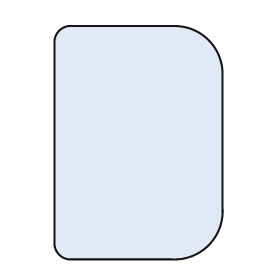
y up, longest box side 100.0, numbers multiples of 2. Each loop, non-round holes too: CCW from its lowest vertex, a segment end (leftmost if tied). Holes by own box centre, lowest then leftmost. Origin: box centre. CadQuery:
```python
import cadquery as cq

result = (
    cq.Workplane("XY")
    .moveTo(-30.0, -50.0)
    .lineTo(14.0, -50.0)
    .threePointArc((30.0, -44.0), (36.0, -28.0))
    .lineTo(36.0, 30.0)
    .threePointArc((30.0, 44.0), (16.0, 50.0))
    .lineTo(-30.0, 50.0)
    .threePointArc((-34.0, 48.0), (-36.0, 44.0))
    .lineTo(-36.0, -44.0)
    .threePointArc((-34.0, -48.0), (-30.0, -50.0))
    .close()
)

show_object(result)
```